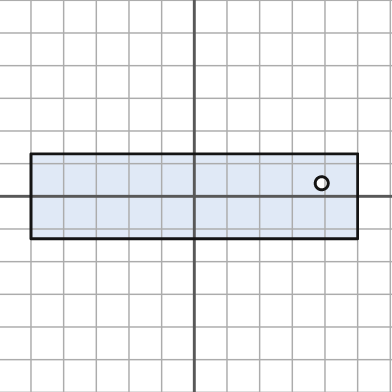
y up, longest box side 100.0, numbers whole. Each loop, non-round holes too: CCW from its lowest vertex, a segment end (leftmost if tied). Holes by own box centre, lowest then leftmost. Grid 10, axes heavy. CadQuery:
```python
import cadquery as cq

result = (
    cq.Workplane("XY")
    .moveTo(-50.0, -13.0)
    .lineTo(50.0, -13.0)
    .lineTo(50.0, 13.0)
    .lineTo(-50.0, 13.0)
    .close()
    .moveTo(39.0, 4.0)
    .circle(2.0)
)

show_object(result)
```